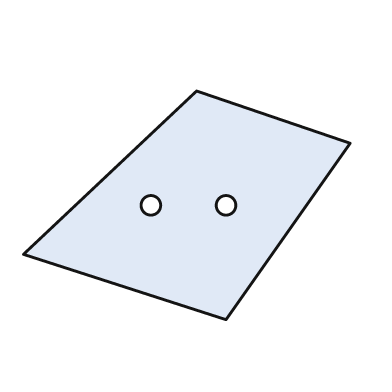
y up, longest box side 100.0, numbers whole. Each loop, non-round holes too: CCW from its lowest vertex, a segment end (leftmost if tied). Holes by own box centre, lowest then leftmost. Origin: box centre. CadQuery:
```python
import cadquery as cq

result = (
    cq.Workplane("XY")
    .moveTo(12.0, -35.0)
    .lineTo(50.0, 19.0)
    .lineTo(3.0, 35.0)
    .lineTo(-50.0, -15.0)
    .close()
    .moveTo(-11.0, 0.0)
    .circle(3.0)
    .moveTo(12.0, 0.0)
    .circle(3.0)
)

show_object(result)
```